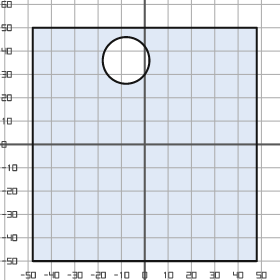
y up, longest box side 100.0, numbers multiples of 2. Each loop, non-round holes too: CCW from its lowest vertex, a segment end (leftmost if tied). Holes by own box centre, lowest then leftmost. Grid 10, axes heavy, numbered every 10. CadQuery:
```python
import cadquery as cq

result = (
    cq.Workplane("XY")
    .moveTo(-48.0, -50.0)
    .lineTo(48.0, -50.0)
    .lineTo(48.0, 50.0)
    .lineTo(-48.0, 50.0)
    .close()
    .moveTo(-8.0, 36.0)
    .circle(10.0)
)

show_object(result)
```